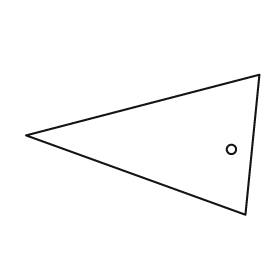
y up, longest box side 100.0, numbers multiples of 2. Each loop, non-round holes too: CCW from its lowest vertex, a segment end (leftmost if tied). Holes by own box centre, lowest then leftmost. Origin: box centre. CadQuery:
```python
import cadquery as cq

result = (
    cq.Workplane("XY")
    .moveTo(44.0, -30.0)
    .lineTo(50.0, 30.0)
    .lineTo(-50.0, 4.0)
    .close()
    .moveTo(38.0, -2.0)
    .circle(2.0)
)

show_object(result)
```